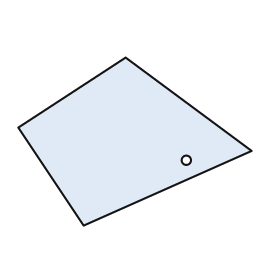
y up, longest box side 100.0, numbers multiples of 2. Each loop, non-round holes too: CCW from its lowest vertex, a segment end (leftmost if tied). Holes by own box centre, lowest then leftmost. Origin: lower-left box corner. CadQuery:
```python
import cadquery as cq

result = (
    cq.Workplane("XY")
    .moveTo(28.0, 0.0)
    .lineTo(100.0, 32.0)
    .lineTo(46.0, 72.0)
    .lineTo(0.0, 42.0)
    .close()
    .moveTo(72.0, 28.0)
    .circle(2.0)
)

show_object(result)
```